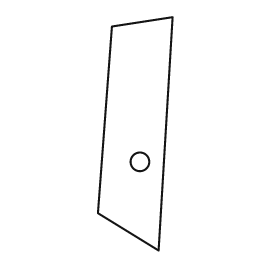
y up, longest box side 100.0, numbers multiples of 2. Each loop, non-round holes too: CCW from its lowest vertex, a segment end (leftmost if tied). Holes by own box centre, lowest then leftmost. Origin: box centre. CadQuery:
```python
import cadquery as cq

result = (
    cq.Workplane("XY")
    .moveTo(10.0, -50.0)
    .lineTo(16.0, 50.0)
    .lineTo(-10.0, 46.0)
    .lineTo(-16.0, -34.0)
    .close()
    .moveTo(2.0, -12.0)
    .circle(4.0)
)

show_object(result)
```